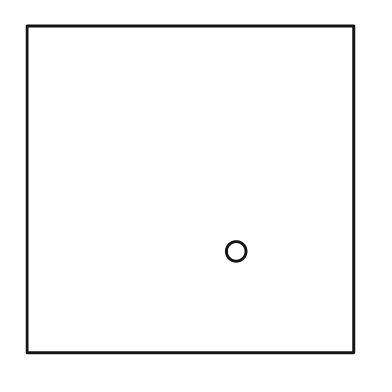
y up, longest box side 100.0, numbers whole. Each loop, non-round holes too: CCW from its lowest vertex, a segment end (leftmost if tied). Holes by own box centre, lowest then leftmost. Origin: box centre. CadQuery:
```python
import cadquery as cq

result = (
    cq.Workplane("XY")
    .moveTo(-50.0, -50.0)
    .lineTo(50.0, -50.0)
    .lineTo(50.0, 50.0)
    .lineTo(-50.0, 50.0)
    .close()
    .moveTo(14.0, -19.0)
    .circle(3.0)
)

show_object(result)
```